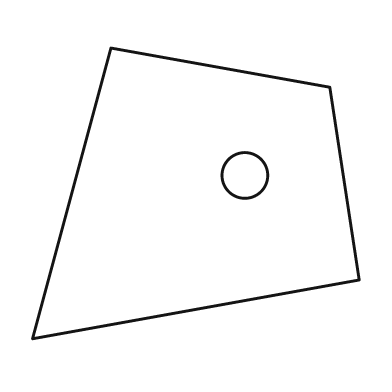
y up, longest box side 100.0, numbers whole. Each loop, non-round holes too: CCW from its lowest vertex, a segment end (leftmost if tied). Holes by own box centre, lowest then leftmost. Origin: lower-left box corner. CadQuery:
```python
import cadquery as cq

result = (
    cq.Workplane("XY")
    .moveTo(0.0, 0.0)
    .lineTo(100.0, 18.0)
    .lineTo(91.0, 77.0)
    .lineTo(24.0, 89.0)
    .close()
    .moveTo(65.0, 50.0)
    .circle(7.0)
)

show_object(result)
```